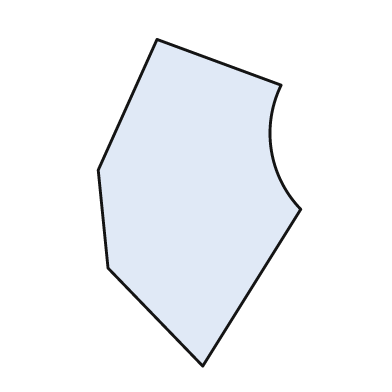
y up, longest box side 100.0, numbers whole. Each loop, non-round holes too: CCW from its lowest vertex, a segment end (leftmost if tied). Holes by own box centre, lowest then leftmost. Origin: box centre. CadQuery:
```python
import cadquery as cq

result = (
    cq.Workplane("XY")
    .moveTo(1.0, -50.0)
    .lineTo(31.0, -2.0)
    .threePointArc((22.0, 16.0), (25.0, 36.0))
    .lineTo(-13.0, 50.0)
    .lineTo(-31.0, 10.0)
    .lineTo(-28.0, -20.0)
    .close()
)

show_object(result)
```